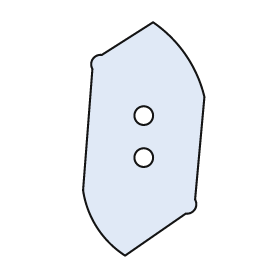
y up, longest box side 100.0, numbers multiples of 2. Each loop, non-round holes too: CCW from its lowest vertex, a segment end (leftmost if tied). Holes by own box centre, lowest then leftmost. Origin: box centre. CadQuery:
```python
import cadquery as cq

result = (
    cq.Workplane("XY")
    .moveTo(-8.0, -50.0)
    .lineTo(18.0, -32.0)
    .threePointArc((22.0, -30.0), (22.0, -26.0))
    .lineTo(26.0, 18.0)
    .threePointArc((18.0, 36.0), (4.0, 50.0))
    .lineTo(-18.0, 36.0)
    .threePointArc((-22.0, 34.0), (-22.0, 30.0))
    .lineTo(-26.0, -22.0)
    .threePointArc((-20.0, -38.0), (-8.0, -50.0))
    .close()
    .moveTo(0.0, -8.0)
    .circle(4.0)
    .moveTo(0.0, 10.0)
    .circle(4.0)
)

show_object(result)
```